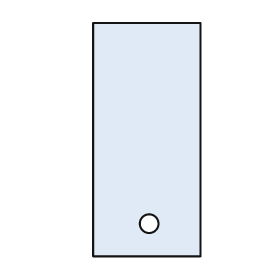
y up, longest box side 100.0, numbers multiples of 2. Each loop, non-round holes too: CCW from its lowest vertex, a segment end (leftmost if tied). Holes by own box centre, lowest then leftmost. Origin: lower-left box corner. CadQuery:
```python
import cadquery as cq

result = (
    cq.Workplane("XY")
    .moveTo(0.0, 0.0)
    .lineTo(46.0, 0.0)
    .lineTo(46.0, 100.0)
    .lineTo(0.0, 100.0)
    .close()
    .moveTo(24.0, 14.0)
    .circle(4.0)
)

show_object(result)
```